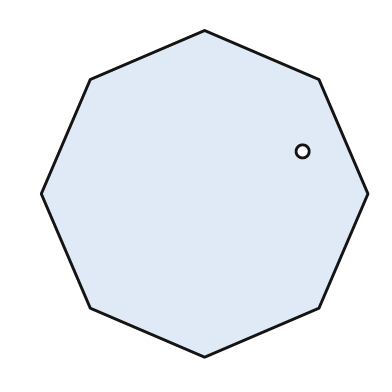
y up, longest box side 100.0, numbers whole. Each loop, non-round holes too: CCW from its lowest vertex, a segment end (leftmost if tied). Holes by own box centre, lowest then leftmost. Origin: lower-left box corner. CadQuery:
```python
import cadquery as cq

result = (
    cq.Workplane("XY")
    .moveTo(50.0, 0.0)
    .lineTo(85.0, 15.0)
    .lineTo(100.0, 50.0)
    .lineTo(85.0, 85.0)
    .lineTo(50.0, 100.0)
    .lineTo(15.0, 85.0)
    .lineTo(0.0, 50.0)
    .lineTo(15.0, 15.0)
    .close()
    .moveTo(80.0, 63.0)
    .circle(2.0)
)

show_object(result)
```